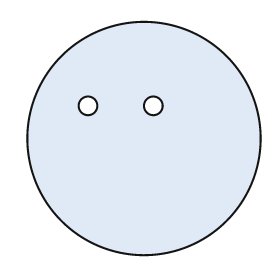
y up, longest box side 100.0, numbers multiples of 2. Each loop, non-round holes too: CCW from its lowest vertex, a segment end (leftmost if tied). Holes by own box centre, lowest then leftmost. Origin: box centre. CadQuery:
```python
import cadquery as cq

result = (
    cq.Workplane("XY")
    .moveTo(0.0, 0.0)
    .circle(50.0)
    .moveTo(-24.0, 14.0)
    .circle(4.0)
    .moveTo(4.0, 14.0)
    .circle(4.0)
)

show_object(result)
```